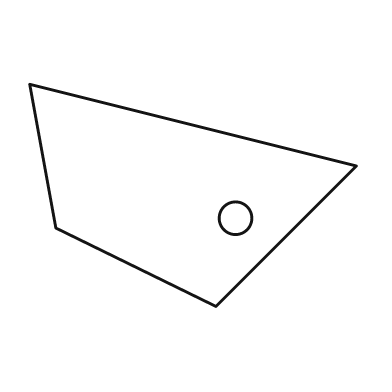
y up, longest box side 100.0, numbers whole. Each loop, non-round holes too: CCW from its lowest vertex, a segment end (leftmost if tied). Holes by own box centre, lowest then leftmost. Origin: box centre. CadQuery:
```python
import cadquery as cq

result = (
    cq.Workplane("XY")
    .moveTo(7.0, -34.0)
    .lineTo(50.0, 9.0)
    .lineTo(-50.0, 34.0)
    .lineTo(-42.0, -10.0)
    .close()
    .moveTo(13.0, -7.0)
    .circle(5.0)
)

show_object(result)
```